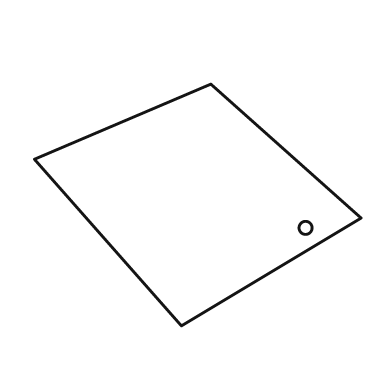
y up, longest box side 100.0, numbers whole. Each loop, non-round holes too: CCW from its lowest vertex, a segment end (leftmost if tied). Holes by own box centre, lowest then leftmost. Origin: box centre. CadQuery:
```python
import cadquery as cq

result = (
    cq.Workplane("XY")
    .moveTo(-5.0, -37.0)
    .lineTo(50.0, -4.0)
    .lineTo(4.0, 37.0)
    .lineTo(-50.0, 14.0)
    .close()
    .moveTo(33.0, -7.0)
    .circle(2.0)
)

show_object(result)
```